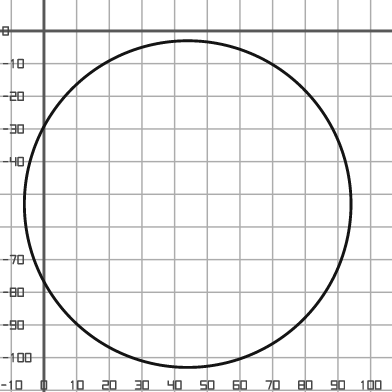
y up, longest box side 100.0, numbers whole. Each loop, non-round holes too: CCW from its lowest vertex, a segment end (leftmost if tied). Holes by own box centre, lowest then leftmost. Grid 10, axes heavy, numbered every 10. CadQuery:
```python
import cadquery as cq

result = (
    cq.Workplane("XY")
    .moveTo(44.0, -53.0)
    .circle(50.0)
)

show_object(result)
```